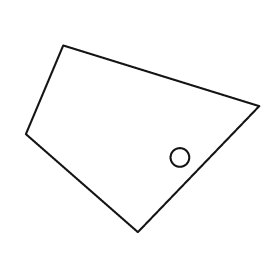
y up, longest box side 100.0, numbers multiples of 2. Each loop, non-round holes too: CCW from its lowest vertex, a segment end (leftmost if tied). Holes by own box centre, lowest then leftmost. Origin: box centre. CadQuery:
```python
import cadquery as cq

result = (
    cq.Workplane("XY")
    .moveTo(-2.0, -40.0)
    .lineTo(50.0, 14.0)
    .lineTo(-34.0, 40.0)
    .lineTo(-50.0, 2.0)
    .close()
    .moveTo(16.0, -8.0)
    .circle(4.0)
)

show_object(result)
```